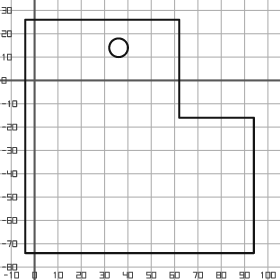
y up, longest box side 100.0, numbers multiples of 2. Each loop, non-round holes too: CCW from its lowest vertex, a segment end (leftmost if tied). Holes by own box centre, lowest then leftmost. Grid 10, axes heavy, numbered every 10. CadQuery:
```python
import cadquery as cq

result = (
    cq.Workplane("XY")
    .moveTo(-4.0, -74.0)
    .lineTo(94.0, -74.0)
    .lineTo(94.0, -16.0)
    .lineTo(62.0, -16.0)
    .lineTo(62.0, 26.0)
    .lineTo(-4.0, 26.0)
    .close()
    .moveTo(36.0, 14.0)
    .circle(4.0)
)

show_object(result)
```